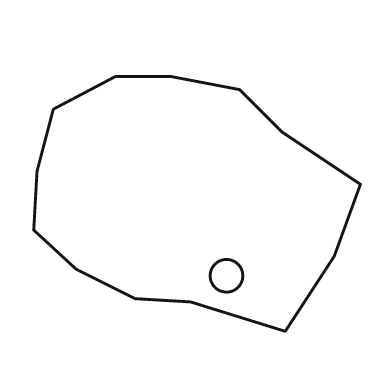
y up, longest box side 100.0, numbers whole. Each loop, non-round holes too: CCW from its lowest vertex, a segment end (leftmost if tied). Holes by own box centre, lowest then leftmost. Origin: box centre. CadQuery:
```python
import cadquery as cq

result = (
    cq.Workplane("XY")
    .moveTo(27.0, -39.0)
    .lineTo(42.0, -16.0)
    .lineTo(50.0, 6.0)
    .lineTo(26.0, 22.0)
    .lineTo(13.0, 35.0)
    .lineTo(-8.0, 39.0)
    .lineTo(-25.0, 39.0)
    .lineTo(-44.0, 29.0)
    .lineTo(-49.0, 10.0)
    .lineTo(-50.0, -8.0)
    .lineTo(-37.0, -20.0)
    .lineTo(-19.0, -29.0)
    .lineTo(-2.0, -30.0)
    .close()
    .moveTo(9.0, -22.0)
    .circle(5.0)
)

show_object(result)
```